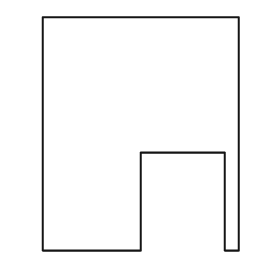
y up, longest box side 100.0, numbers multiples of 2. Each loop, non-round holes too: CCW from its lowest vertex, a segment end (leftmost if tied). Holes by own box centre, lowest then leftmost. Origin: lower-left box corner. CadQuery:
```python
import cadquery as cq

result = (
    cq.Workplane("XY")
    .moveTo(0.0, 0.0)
    .lineTo(42.0, 0.0)
    .lineTo(42.0, 42.0)
    .lineTo(78.0, 42.0)
    .lineTo(78.0, 0.0)
    .lineTo(84.0, 0.0)
    .lineTo(84.0, 100.0)
    .lineTo(0.0, 100.0)
    .close()
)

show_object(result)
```